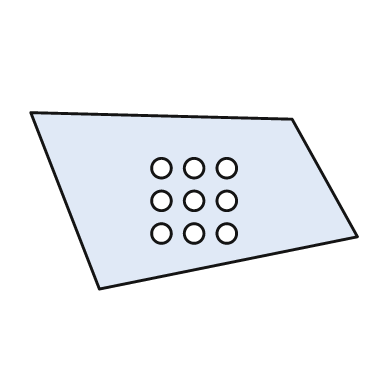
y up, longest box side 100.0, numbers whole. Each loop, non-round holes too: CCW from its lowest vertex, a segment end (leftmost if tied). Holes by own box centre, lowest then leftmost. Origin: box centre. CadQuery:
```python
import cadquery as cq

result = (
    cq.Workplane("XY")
    .moveTo(-29.0, -27.0)
    .lineTo(50.0, -11.0)
    .lineTo(30.0, 25.0)
    .lineTo(-50.0, 27.0)
    .close()
    .moveTo(-10.0, -10.0)
    .circle(3.0)
    .moveTo(0.0, -10.0)
    .circle(3.0)
    .moveTo(10.0, -10.0)
    .circle(3.0)
    .moveTo(-10.0, 0.0)
    .circle(3.0)
    .moveTo(0.0, 0.0)
    .circle(3.0)
    .moveTo(10.0, 0.0)
    .circle(3.0)
    .moveTo(-10.0, 10.0)
    .circle(3.0)
    .moveTo(0.0, 10.0)
    .circle(3.0)
    .moveTo(10.0, 10.0)
    .circle(3.0)
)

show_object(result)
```